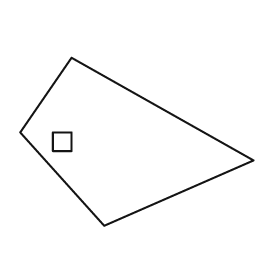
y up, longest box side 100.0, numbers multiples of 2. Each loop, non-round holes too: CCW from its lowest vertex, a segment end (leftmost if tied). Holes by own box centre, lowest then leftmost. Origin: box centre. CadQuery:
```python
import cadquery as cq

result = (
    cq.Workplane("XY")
    .moveTo(-14.0, -36.0)
    .lineTo(50.0, -8.0)
    .lineTo(-28.0, 36.0)
    .lineTo(-50.0, 4.0)
    .close()
    .moveTo(-36.0, -4.0)
    .lineTo(-28.0, -4.0)
    .lineTo(-28.0, 4.0)
    .lineTo(-36.0, 4.0)
    .close()
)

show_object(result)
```